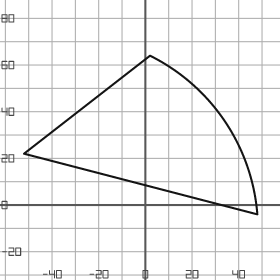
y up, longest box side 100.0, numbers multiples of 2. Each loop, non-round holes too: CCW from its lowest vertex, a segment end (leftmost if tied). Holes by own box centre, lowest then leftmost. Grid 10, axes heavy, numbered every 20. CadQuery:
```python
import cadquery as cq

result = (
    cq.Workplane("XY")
    .moveTo(48.0, -4.0)
    .threePointArc((34.0, 36.0), (2.0, 64.0))
    .lineTo(-52.0, 22.0)
    .close()
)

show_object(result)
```